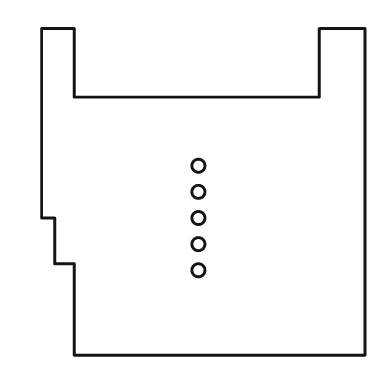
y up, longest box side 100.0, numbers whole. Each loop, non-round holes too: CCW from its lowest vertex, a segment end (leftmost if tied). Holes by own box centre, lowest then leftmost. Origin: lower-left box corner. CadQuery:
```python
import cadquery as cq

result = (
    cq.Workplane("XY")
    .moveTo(10.0, 0.0)
    .lineTo(99.0, 0.0)
    .lineTo(99.0, 100.0)
    .lineTo(85.0, 100.0)
    .lineTo(85.0, 79.0)
    .lineTo(10.0, 79.0)
    .lineTo(10.0, 100.0)
    .lineTo(0.0, 100.0)
    .lineTo(0.0, 42.0)
    .lineTo(4.0, 42.0)
    .lineTo(4.0, 28.0)
    .lineTo(10.0, 28.0)
    .close()
    .moveTo(48.0, 26.0)
    .circle(2.0)
    .moveTo(48.0, 34.0)
    .circle(2.0)
    .moveTo(48.0, 42.0)
    .circle(2.0)
    .moveTo(48.0, 50.0)
    .circle(2.0)
    .moveTo(48.0, 58.0)
    .circle(2.0)
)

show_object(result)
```